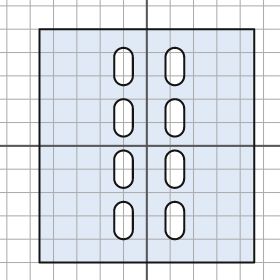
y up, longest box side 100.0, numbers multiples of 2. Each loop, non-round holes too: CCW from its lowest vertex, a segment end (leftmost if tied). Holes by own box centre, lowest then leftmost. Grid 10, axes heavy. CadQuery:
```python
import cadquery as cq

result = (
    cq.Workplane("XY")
    .moveTo(-46.0, -50.0)
    .lineTo(46.0, -50.0)
    .lineTo(46.0, 50.0)
    .lineTo(-46.0, 50.0)
    .close()
    .moveTo(-14.0, -36.0)
    .threePointArc((-10.0, -40.0), (-6.0, -36.0))
    .lineTo(-6.0, -28.0)
    .threePointArc((-10.0, -24.0), (-14.0, -28.0))
    .close()
    .moveTo(8.0, -36.0)
    .threePointArc((12.0, -40.0), (16.0, -36.0))
    .lineTo(16.0, -28.0)
    .threePointArc((12.0, -24.0), (8.0, -28.0))
    .close()
    .moveTo(-14.0, -14.0)
    .threePointArc((-10.0, -18.0), (-6.0, -14.0))
    .lineTo(-6.0, -6.0)
    .threePointArc((-10.0, -2.0), (-14.0, -6.0))
    .close()
    .moveTo(8.0, -14.0)
    .threePointArc((12.0, -18.0), (16.0, -14.0))
    .lineTo(16.0, -6.0)
    .threePointArc((12.0, -2.0), (8.0, -6.0))
    .close()
    .moveTo(-14.0, 8.0)
    .threePointArc((-10.0, 4.0), (-6.0, 8.0))
    .lineTo(-6.0, 16.0)
    .threePointArc((-10.0, 20.0), (-14.0, 16.0))
    .close()
    .moveTo(8.0, 8.0)
    .threePointArc((12.0, 4.0), (16.0, 8.0))
    .lineTo(16.0, 16.0)
    .threePointArc((12.0, 20.0), (8.0, 16.0))
    .close()
    .moveTo(-14.0, 30.0)
    .threePointArc((-10.0, 26.0), (-6.0, 30.0))
    .lineTo(-6.0, 38.0)
    .threePointArc((-10.0, 42.0), (-14.0, 38.0))
    .close()
    .moveTo(8.0, 30.0)
    .threePointArc((12.0, 26.0), (16.0, 30.0))
    .lineTo(16.0, 38.0)
    .threePointArc((12.0, 42.0), (8.0, 38.0))
    .close()
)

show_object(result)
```